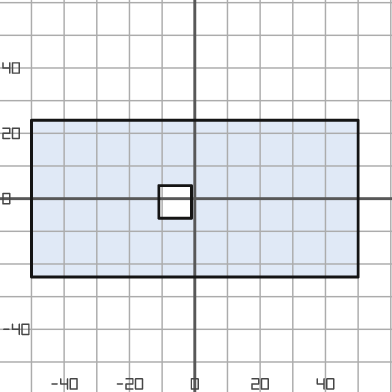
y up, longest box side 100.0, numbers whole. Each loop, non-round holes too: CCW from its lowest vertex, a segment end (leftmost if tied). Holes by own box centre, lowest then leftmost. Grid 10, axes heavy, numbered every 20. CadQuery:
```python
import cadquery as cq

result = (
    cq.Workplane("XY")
    .moveTo(-50.0, -24.0)
    .lineTo(50.0, -24.0)
    .lineTo(50.0, 24.0)
    .lineTo(-50.0, 24.0)
    .close()
    .moveTo(-11.0, -6.0)
    .lineTo(-1.0, -6.0)
    .lineTo(-1.0, 4.0)
    .lineTo(-11.0, 4.0)
    .close()
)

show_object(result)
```